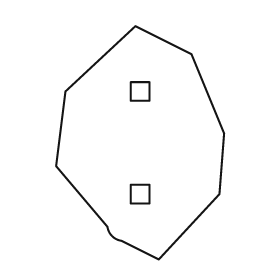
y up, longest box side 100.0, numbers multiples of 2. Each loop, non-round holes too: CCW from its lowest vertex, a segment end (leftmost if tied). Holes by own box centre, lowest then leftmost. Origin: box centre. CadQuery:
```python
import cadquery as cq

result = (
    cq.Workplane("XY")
    .moveTo(8.0, -50.0)
    .lineTo(34.0, -22.0)
    .lineTo(36.0, 4.0)
    .lineTo(22.0, 38.0)
    .lineTo(-2.0, 50.0)
    .lineTo(-32.0, 22.0)
    .lineTo(-36.0, -10.0)
    .lineTo(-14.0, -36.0)
    .threePointArc((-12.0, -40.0), (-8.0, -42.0))
    .close()
    .moveTo(-4.0, -26.0)
    .lineTo(4.0, -26.0)
    .lineTo(4.0, -18.0)
    .lineTo(-4.0, -18.0)
    .close()
    .moveTo(-4.0, 18.0)
    .lineTo(4.0, 18.0)
    .lineTo(4.0, 26.0)
    .lineTo(-4.0, 26.0)
    .close()
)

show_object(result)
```